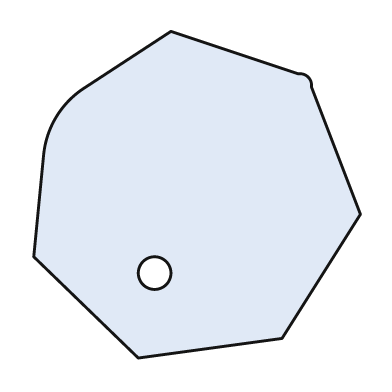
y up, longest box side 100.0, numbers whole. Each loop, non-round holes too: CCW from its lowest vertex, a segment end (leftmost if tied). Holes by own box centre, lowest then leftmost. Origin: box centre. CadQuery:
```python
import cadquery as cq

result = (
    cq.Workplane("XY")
    .moveTo(-18.0, -50.0)
    .lineTo(26.0, -44.0)
    .lineTo(50.0, -6.0)
    .lineTo(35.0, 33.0)
    .threePointArc((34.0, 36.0), (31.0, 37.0))
    .lineTo(-8.0, 50.0)
    .lineTo(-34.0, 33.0)
    .threePointArc((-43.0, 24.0), (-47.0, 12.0))
    .lineTo(-50.0, -19.0)
    .close()
    .moveTo(-13.0, -24.0)
    .circle(5.0)
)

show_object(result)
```